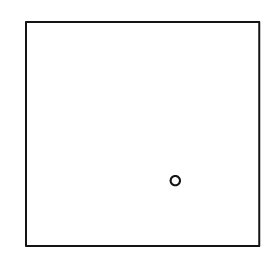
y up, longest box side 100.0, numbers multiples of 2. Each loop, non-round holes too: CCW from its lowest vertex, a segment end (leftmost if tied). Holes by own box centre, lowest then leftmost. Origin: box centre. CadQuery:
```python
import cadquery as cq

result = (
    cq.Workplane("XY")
    .moveTo(-50.0, -48.0)
    .lineTo(50.0, -48.0)
    .lineTo(50.0, 48.0)
    .lineTo(-50.0, 48.0)
    .close()
    .moveTo(14.0, -20.0)
    .circle(2.0)
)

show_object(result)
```